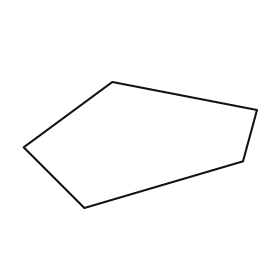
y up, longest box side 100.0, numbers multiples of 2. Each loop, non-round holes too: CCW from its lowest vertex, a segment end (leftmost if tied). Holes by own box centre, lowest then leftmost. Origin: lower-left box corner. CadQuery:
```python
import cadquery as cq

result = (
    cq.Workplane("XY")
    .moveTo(26.0, 0.0)
    .lineTo(94.0, 20.0)
    .lineTo(100.0, 42.0)
    .lineTo(38.0, 54.0)
    .lineTo(0.0, 26.0)
    .close()
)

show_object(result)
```